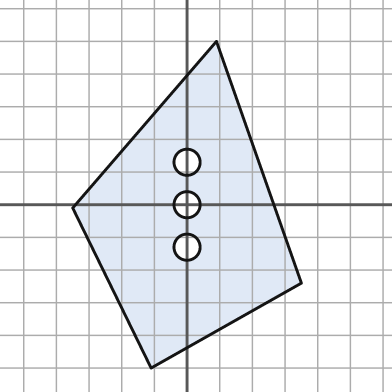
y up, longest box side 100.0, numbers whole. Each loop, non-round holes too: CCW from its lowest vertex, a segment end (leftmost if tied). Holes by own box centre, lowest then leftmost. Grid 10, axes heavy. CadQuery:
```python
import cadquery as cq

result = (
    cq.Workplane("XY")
    .moveTo(-11.0, -50.0)
    .lineTo(35.0, -24.0)
    .lineTo(9.0, 50.0)
    .lineTo(-35.0, -1.0)
    .close()
    .moveTo(0.0, -13.0)
    .circle(4.0)
    .moveTo(0.0, 0.0)
    .circle(4.0)
    .moveTo(0.0, 13.0)
    .circle(4.0)
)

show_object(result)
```